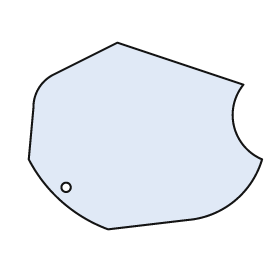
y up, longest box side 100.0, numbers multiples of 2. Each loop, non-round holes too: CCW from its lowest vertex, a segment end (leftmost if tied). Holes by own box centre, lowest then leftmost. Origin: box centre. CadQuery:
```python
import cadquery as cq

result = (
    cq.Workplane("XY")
    .moveTo(-16.0, -40.0)
    .lineTo(18.0, -36.0)
    .threePointArc((38.0, -28.0), (50.0, -10.0))
    .threePointArc((38.0, 4.0), (42.0, 22.0))
    .lineTo(-12.0, 40.0)
    .lineTo(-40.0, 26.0)
    .threePointArc((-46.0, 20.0), (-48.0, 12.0))
    .lineTo(-50.0, -10.0)
    .threePointArc((-36.0, -28.0), (-16.0, -40.0))
    .close()
    .moveTo(-34.0, -22.0)
    .circle(2.0)
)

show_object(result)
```